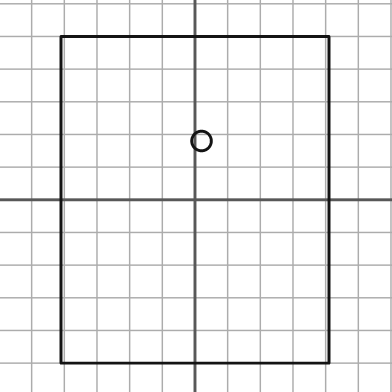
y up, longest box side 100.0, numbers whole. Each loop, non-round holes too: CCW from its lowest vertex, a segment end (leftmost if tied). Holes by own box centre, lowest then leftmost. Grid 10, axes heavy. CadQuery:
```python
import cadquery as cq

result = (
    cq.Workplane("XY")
    .moveTo(-41.0, -50.0)
    .lineTo(41.0, -50.0)
    .lineTo(41.0, 50.0)
    .lineTo(-41.0, 50.0)
    .close()
    .moveTo(2.0, 18.0)
    .circle(3.0)
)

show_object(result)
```